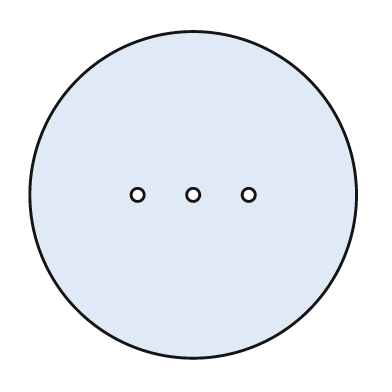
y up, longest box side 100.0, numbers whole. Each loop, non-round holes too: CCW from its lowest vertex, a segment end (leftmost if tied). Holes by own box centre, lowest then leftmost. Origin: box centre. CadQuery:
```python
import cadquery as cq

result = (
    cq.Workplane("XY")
    .moveTo(0.0, 0.0)
    .circle(50.0)
    .moveTo(-17.0, 0.0)
    .circle(2.0)
    .moveTo(0.0, 0.0)
    .circle(2.0)
    .moveTo(17.0, 0.0)
    .circle(2.0)
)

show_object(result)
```